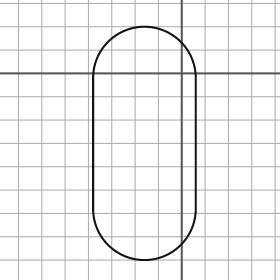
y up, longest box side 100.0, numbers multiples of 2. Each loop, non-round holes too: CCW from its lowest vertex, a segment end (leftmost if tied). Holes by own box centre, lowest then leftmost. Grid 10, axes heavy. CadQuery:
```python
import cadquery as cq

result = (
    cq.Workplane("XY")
    .moveTo(-38.0, -58.0)
    .threePointArc((-16.0, -80.0), (6.0, -58.0))
    .lineTo(6.0, -2.0)
    .threePointArc((-16.0, 20.0), (-38.0, -2.0))
    .close()
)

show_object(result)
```